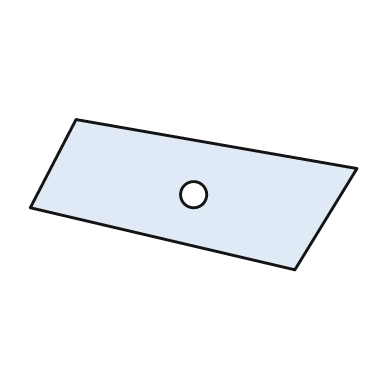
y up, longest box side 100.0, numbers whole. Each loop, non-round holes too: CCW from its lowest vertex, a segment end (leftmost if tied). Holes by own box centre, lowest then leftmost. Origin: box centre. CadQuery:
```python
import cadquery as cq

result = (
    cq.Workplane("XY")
    .moveTo(31.0, -23.0)
    .lineTo(50.0, 8.0)
    .lineTo(-36.0, 23.0)
    .lineTo(-50.0, -4.0)
    .close()
    .moveTo(0.0, 0.0)
    .circle(4.0)
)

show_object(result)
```